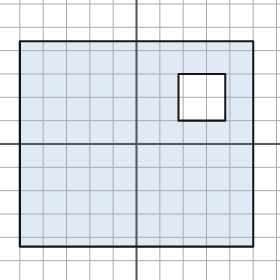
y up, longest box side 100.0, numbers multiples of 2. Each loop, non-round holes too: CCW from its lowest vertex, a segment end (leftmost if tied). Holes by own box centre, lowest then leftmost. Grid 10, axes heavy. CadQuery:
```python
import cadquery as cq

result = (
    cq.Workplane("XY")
    .moveTo(-50.0, -44.0)
    .lineTo(50.0, -44.0)
    .lineTo(50.0, 44.0)
    .lineTo(-50.0, 44.0)
    .close()
    .moveTo(18.0, 10.0)
    .lineTo(38.0, 10.0)
    .lineTo(38.0, 30.0)
    .lineTo(18.0, 30.0)
    .close()
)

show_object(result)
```